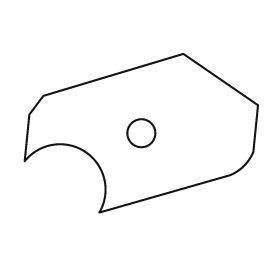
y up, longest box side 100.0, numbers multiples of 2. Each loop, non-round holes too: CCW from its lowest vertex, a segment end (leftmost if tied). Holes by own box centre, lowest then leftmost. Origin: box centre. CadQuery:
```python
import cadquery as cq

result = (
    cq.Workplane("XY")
    .moveTo(-18.0, -34.0)
    .lineTo(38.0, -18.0)
    .threePointArc((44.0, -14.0), (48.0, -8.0))
    .lineTo(50.0, 12.0)
    .lineTo(18.0, 34.0)
    .lineTo(-42.0, 16.0)
    .lineTo(-48.0, 8.0)
    .lineTo(-50.0, -12.0)
    .threePointArc((-24.0, -8.0), (-18.0, -34.0))
    .close()
    .moveTo(0.0, 0.0)
    .circle(6.0)
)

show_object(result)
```